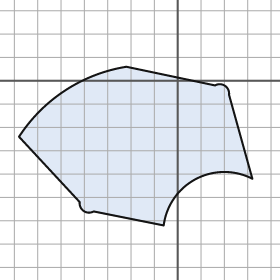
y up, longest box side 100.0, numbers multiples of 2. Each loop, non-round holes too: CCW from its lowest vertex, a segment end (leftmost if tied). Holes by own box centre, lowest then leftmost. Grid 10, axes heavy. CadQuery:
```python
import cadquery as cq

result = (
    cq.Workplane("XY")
    .moveTo(-6.0, -62.0)
    .threePointArc((8.0, -42.0), (32.0, -42.0))
    .lineTo(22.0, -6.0)
    .threePointArc((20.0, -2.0), (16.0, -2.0))
    .lineTo(-22.0, 6.0)
    .threePointArc((-48.0, -4.0), (-68.0, -24.0))
    .lineTo(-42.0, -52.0)
    .threePointArc((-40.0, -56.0), (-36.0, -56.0))
    .close()
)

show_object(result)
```